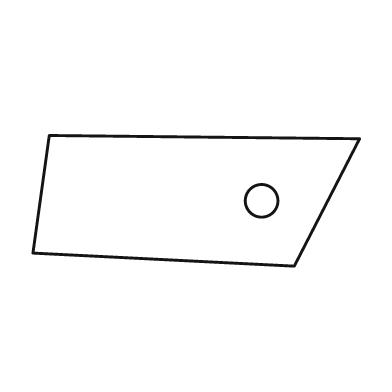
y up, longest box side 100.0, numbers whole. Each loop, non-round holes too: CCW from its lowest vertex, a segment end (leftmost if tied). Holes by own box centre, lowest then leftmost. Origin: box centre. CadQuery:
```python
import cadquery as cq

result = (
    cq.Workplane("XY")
    .moveTo(30.0, -20.0)
    .lineTo(50.0, 19.0)
    .lineTo(-45.0, 20.0)
    .lineTo(-50.0, -16.0)
    .close()
    .moveTo(20.0, 0.0)
    .circle(5.0)
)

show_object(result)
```